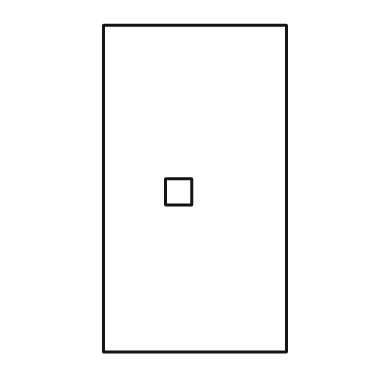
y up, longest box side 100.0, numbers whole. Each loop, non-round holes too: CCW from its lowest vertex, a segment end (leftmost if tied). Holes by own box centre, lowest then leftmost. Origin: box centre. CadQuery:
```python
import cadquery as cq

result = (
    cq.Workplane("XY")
    .moveTo(-28.0, -50.0)
    .lineTo(28.0, -50.0)
    .lineTo(28.0, 50.0)
    .lineTo(-28.0, 50.0)
    .close()
    .moveTo(-9.0, -5.0)
    .lineTo(-1.0, -5.0)
    .lineTo(-1.0, 3.0)
    .lineTo(-9.0, 3.0)
    .close()
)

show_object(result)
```